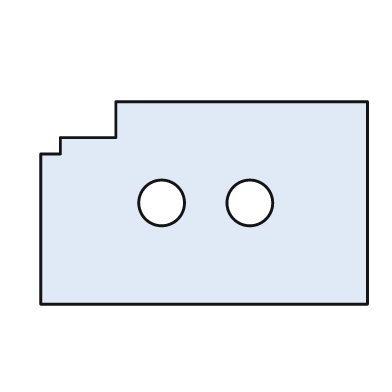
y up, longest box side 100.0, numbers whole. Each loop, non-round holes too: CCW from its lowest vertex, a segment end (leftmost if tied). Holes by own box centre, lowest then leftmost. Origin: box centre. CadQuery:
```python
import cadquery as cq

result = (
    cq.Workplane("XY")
    .moveTo(-50.0, -31.0)
    .lineTo(50.0, -31.0)
    .lineTo(50.0, 31.0)
    .lineTo(-27.0, 31.0)
    .lineTo(-27.0, 20.0)
    .lineTo(-44.0, 20.0)
    .lineTo(-44.0, 15.0)
    .lineTo(-50.0, 15.0)
    .close()
    .moveTo(-13.0, 0.0)
    .circle(7.0)
    .moveTo(14.0, 0.0)
    .circle(7.0)
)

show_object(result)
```